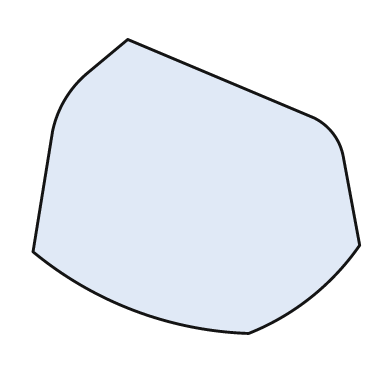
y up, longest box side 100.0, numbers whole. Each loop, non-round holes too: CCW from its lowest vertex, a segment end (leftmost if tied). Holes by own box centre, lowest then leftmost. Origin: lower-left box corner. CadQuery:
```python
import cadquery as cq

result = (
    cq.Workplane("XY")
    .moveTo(66.0, 0.0)
    .threePointArc((85.0, 11.0), (100.0, 27.0))
    .lineTo(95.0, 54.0)
    .threePointArc((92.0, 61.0), (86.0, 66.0))
    .lineTo(29.0, 90.0)
    .lineTo(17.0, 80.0)
    .threePointArc((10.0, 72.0), (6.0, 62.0))
    .lineTo(0.0, 25.0)
    .threePointArc((31.0, 7.0), (66.0, 0.0))
    .close()
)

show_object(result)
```